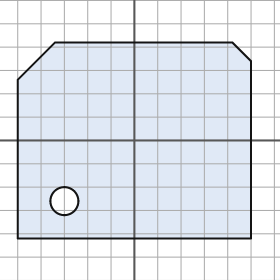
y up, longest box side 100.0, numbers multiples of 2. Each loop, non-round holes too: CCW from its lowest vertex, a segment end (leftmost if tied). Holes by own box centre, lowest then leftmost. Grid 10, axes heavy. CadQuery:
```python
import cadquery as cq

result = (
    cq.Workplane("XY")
    .moveTo(-50.0, -42.0)
    .lineTo(50.0, -42.0)
    .lineTo(50.0, 34.0)
    .lineTo(42.0, 42.0)
    .lineTo(-34.0, 42.0)
    .lineTo(-50.0, 26.0)
    .close()
    .moveTo(-30.0, -26.0)
    .circle(6.0)
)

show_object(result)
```